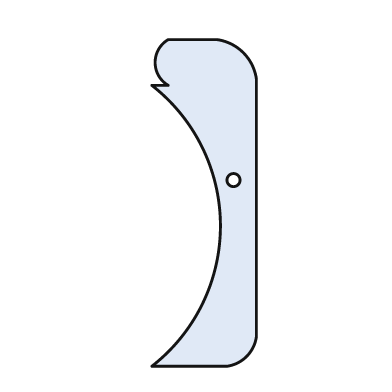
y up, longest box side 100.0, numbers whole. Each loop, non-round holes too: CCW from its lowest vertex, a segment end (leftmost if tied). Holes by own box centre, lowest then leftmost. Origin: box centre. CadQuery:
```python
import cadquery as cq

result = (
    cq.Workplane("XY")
    .moveTo(-16.0, -50.0)
    .lineTo(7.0, -50.0)
    .threePointArc((13.0, -47.0), (16.0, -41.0))
    .lineTo(16.0, 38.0)
    .threePointArc((12.0, 46.0), (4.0, 50.0))
    .lineTo(-11.0, 50.0)
    .threePointArc((-15.0, 43.0), (-11.0, 36.0))
    .lineTo(-16.0, 36.0)
    .threePointArc((5.0, -7.0), (-16.0, -50.0))
    .close()
    .moveTo(9.0, 7.0)
    .circle(2.0)
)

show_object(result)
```